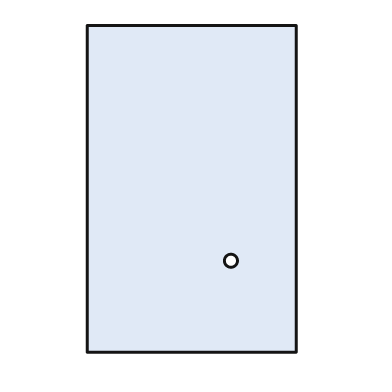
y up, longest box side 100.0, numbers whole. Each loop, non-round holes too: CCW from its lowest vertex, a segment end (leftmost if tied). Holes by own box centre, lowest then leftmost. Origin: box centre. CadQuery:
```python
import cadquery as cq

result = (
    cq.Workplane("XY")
    .moveTo(-32.0, -50.0)
    .lineTo(32.0, -50.0)
    .lineTo(32.0, 50.0)
    .lineTo(-32.0, 50.0)
    .close()
    .moveTo(12.0, -22.0)
    .circle(2.0)
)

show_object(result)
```